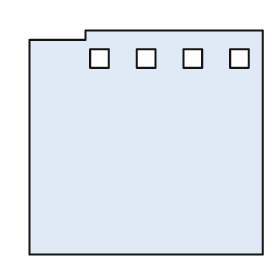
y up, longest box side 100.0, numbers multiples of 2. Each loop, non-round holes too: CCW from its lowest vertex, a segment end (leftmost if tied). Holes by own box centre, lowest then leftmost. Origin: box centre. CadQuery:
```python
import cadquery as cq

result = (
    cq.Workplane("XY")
    .moveTo(-50.0, -48.0)
    .lineTo(50.0, -48.0)
    .lineTo(50.0, 48.0)
    .lineTo(-26.0, 48.0)
    .lineTo(-26.0, 44.0)
    .lineTo(-50.0, 44.0)
    .close()
    .moveTo(-24.0, 32.0)
    .lineTo(-16.0, 32.0)
    .lineTo(-16.0, 40.0)
    .lineTo(-24.0, 40.0)
    .close()
    .moveTo(-4.0, 32.0)
    .lineTo(4.0, 32.0)
    .lineTo(4.0, 40.0)
    .lineTo(-4.0, 40.0)
    .close()
    .moveTo(16.0, 32.0)
    .lineTo(24.0, 32.0)
    .lineTo(24.0, 40.0)
    .lineTo(16.0, 40.0)
    .close()
    .moveTo(36.0, 32.0)
    .lineTo(44.0, 32.0)
    .lineTo(44.0, 40.0)
    .lineTo(36.0, 40.0)
    .close()
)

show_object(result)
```